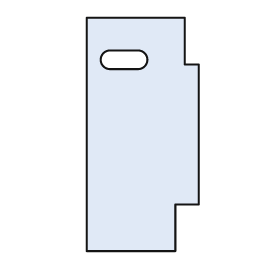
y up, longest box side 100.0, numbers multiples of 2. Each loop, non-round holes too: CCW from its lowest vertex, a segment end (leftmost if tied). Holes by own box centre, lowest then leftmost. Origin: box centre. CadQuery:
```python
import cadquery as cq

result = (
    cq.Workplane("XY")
    .moveTo(-24.0, -50.0)
    .lineTo(14.0, -50.0)
    .lineTo(14.0, -30.0)
    .lineTo(24.0, -30.0)
    .lineTo(24.0, 30.0)
    .lineTo(18.0, 30.0)
    .lineTo(18.0, 50.0)
    .lineTo(-24.0, 50.0)
    .close()
    .moveTo(-14.0, 28.0)
    .lineTo(-2.0, 28.0)
    .threePointArc((2.0, 32.0), (-2.0, 36.0))
    .lineTo(-14.0, 36.0)
    .threePointArc((-18.0, 32.0), (-14.0, 28.0))
    .close()
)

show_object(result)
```